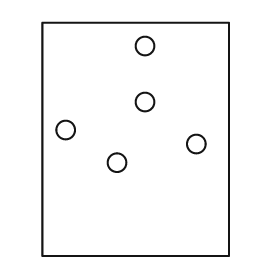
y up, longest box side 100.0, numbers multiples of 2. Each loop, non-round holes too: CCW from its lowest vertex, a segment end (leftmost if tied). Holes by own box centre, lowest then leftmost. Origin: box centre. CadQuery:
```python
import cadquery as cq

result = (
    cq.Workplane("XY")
    .moveTo(-40.0, -50.0)
    .lineTo(40.0, -50.0)
    .lineTo(40.0, 50.0)
    .lineTo(-40.0, 50.0)
    .close()
    .moveTo(-8.0, -10.0)
    .circle(4.0)
    .moveTo(26.0, -2.0)
    .circle(4.0)
    .moveTo(-30.0, 4.0)
    .circle(4.0)
    .moveTo(4.0, 16.0)
    .circle(4.0)
    .moveTo(4.0, 40.0)
    .circle(4.0)
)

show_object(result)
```